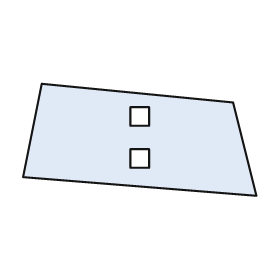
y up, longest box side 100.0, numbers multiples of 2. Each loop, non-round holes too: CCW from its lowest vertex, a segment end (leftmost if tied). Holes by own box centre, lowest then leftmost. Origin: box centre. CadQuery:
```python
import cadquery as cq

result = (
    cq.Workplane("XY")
    .moveTo(50.0, -24.0)
    .lineTo(40.0, 16.0)
    .lineTo(-42.0, 24.0)
    .lineTo(-50.0, -16.0)
    .close()
    .moveTo(-4.0, -12.0)
    .lineTo(4.0, -12.0)
    .lineTo(4.0, -4.0)
    .lineTo(-4.0, -4.0)
    .close()
    .moveTo(-4.0, 6.0)
    .lineTo(4.0, 6.0)
    .lineTo(4.0, 14.0)
    .lineTo(-4.0, 14.0)
    .close()
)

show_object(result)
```